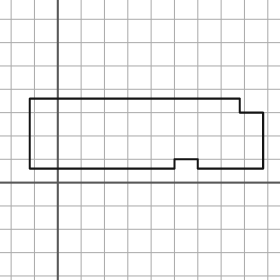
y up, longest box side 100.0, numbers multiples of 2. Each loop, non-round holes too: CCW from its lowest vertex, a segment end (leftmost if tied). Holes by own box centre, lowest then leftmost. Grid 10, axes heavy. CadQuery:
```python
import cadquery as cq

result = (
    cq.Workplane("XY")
    .moveTo(-12.0, 6.0)
    .lineTo(50.0, 6.0)
    .lineTo(50.0, 10.0)
    .lineTo(60.0, 10.0)
    .lineTo(60.0, 6.0)
    .lineTo(88.0, 6.0)
    .lineTo(88.0, 30.0)
    .lineTo(78.0, 30.0)
    .lineTo(78.0, 36.0)
    .lineTo(-12.0, 36.0)
    .close()
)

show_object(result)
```